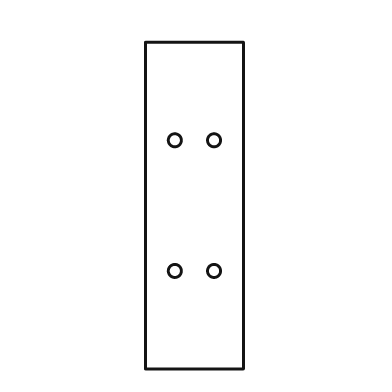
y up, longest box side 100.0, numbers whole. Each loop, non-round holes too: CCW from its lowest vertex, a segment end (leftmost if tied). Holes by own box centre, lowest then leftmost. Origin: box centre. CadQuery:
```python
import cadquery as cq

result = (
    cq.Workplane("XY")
    .moveTo(-15.0, -50.0)
    .lineTo(15.0, -50.0)
    .lineTo(15.0, 50.0)
    .lineTo(-15.0, 50.0)
    .close()
    .moveTo(-6.0, -20.0)
    .circle(2.0)
    .moveTo(6.0, -20.0)
    .circle(2.0)
    .moveTo(-6.0, 20.0)
    .circle(2.0)
    .moveTo(6.0, 20.0)
    .circle(2.0)
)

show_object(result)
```